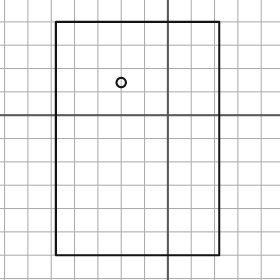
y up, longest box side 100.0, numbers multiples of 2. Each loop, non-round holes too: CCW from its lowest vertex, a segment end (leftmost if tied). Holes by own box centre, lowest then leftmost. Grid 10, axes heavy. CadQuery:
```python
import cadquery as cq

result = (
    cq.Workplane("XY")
    .moveTo(-48.0, -60.0)
    .lineTo(22.0, -60.0)
    .lineTo(22.0, 40.0)
    .lineTo(-48.0, 40.0)
    .close()
    .moveTo(-20.0, 14.0)
    .circle(2.0)
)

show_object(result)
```